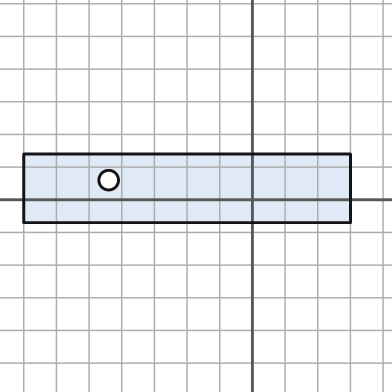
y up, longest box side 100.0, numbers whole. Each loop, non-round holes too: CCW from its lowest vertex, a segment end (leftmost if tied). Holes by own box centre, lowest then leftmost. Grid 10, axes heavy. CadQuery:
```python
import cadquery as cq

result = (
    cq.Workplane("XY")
    .moveTo(-70.0, -7.0)
    .lineTo(30.0, -7.0)
    .lineTo(30.0, 14.0)
    .lineTo(-70.0, 14.0)
    .close()
    .moveTo(-44.0, 6.0)
    .circle(3.0)
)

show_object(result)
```